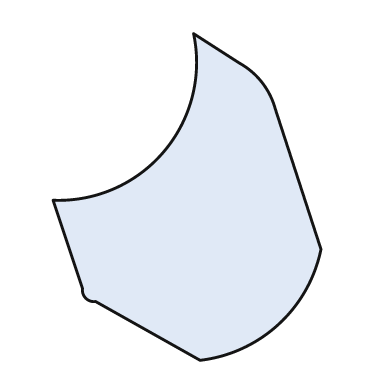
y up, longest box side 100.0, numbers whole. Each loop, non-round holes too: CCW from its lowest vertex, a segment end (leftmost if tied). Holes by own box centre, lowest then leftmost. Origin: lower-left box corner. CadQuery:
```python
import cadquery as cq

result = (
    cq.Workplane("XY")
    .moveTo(45.0, 0.0)
    .threePointArc((69.0, 11.0), (82.0, 34.0))
    .lineTo(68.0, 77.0)
    .threePointArc((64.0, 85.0), (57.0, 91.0))
    .lineTo(43.0, 100.0)
    .threePointArc((34.0, 64.0), (0.0, 49.0))
    .lineTo(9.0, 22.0)
    .threePointArc((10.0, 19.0), (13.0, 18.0))
    .close()
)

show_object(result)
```